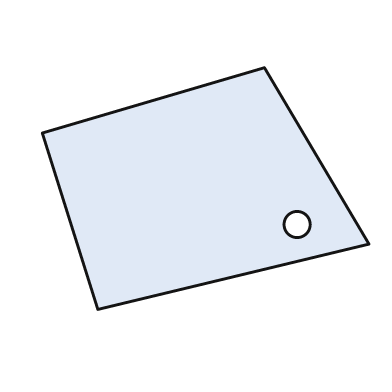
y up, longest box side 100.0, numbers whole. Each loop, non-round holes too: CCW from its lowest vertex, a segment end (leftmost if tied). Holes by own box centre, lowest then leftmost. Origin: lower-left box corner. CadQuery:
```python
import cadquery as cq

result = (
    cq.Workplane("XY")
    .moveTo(17.0, 0.0)
    .lineTo(100.0, 20.0)
    .lineTo(68.0, 74.0)
    .lineTo(0.0, 54.0)
    .close()
    .moveTo(78.0, 26.0)
    .circle(4.0)
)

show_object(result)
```